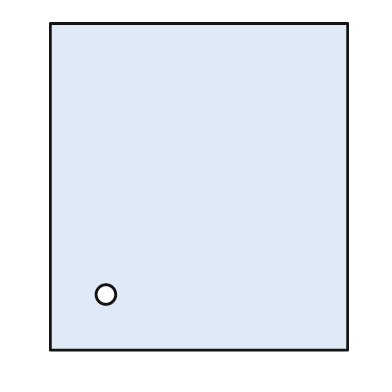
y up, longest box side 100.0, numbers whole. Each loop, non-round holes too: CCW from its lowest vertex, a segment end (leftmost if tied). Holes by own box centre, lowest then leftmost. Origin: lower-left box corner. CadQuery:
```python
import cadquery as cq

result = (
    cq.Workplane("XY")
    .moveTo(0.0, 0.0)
    .lineTo(91.0, 0.0)
    .lineTo(91.0, 100.0)
    .lineTo(0.0, 100.0)
    .close()
    .moveTo(17.0, 17.0)
    .circle(3.0)
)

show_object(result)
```